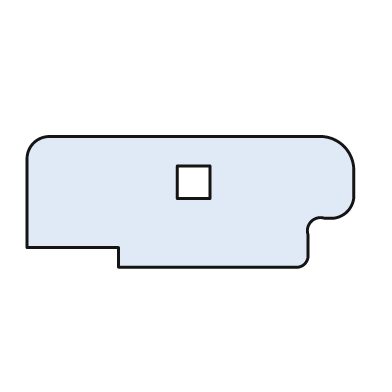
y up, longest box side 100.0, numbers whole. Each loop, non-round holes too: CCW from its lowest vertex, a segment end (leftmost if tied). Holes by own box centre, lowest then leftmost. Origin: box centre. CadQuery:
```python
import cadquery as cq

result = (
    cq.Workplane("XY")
    .moveTo(-22.0, -20.0)
    .lineTo(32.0, -20.0)
    .threePointArc((35.0, -19.0), (36.0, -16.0))
    .lineTo(36.0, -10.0)
    .threePointArc((37.0, -6.0), (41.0, -5.0))
    .lineTo(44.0, -5.0)
    .threePointArc((48.0, -3.0), (50.0, 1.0))
    .lineTo(50.0, 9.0)
    .threePointArc((47.0, 17.0), (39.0, 20.0))
    .lineTo(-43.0, 20.0)
    .threePointArc((-48.0, 18.0), (-50.0, 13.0))
    .lineTo(-50.0, -14.0)
    .lineTo(-22.0, -14.0)
    .close()
    .moveTo(-4.0, 1.0)
    .lineTo(6.0, 1.0)
    .lineTo(6.0, 11.0)
    .lineTo(-4.0, 11.0)
    .close()
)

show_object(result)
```